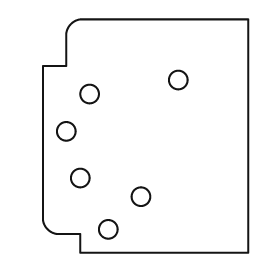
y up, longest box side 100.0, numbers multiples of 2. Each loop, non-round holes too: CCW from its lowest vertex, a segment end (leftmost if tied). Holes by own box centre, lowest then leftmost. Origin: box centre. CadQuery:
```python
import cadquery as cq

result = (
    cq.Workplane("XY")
    .moveTo(-28.0, -50.0)
    .lineTo(44.0, -50.0)
    .lineTo(44.0, 50.0)
    .lineTo(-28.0, 50.0)
    .threePointArc((-32.0, 48.0), (-34.0, 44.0))
    .lineTo(-34.0, 30.0)
    .lineTo(-44.0, 30.0)
    .lineTo(-44.0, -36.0)
    .threePointArc((-42.0, -40.0), (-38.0, -42.0))
    .lineTo(-28.0, -42.0)
    .close()
    .moveTo(-16.0, -40.0)
    .circle(4.0)
    .moveTo(-2.0, -26.0)
    .circle(4.0)
    .moveTo(-28.0, -18.0)
    .circle(4.0)
    .moveTo(-34.0, 2.0)
    .circle(4.0)
    .moveTo(-24.0, 18.0)
    .circle(4.0)
    .moveTo(14.0, 24.0)
    .circle(4.0)
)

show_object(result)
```